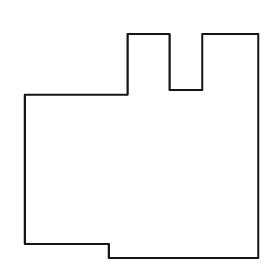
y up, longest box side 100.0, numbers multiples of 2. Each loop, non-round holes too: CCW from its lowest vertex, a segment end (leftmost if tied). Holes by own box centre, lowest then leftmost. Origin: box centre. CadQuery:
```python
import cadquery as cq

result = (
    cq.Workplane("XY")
    .moveTo(-14.0, -48.0)
    .lineTo(50.0, -48.0)
    .lineTo(50.0, 48.0)
    .lineTo(26.0, 48.0)
    .lineTo(26.0, 24.0)
    .lineTo(12.0, 24.0)
    .lineTo(12.0, 48.0)
    .lineTo(-6.0, 48.0)
    .lineTo(-6.0, 22.0)
    .lineTo(-50.0, 22.0)
    .lineTo(-50.0, -42.0)
    .lineTo(-14.0, -42.0)
    .close()
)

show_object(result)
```